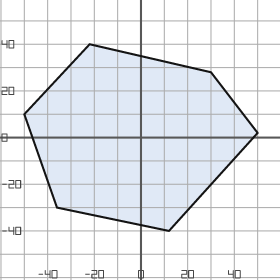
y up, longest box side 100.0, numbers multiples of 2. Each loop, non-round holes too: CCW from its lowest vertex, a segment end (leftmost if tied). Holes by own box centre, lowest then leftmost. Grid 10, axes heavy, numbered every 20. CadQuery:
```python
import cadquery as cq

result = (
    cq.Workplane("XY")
    .moveTo(12.0, -40.0)
    .lineTo(50.0, 2.0)
    .lineTo(30.0, 28.0)
    .lineTo(-22.0, 40.0)
    .lineTo(-50.0, 10.0)
    .lineTo(-36.0, -30.0)
    .close()
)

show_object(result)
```